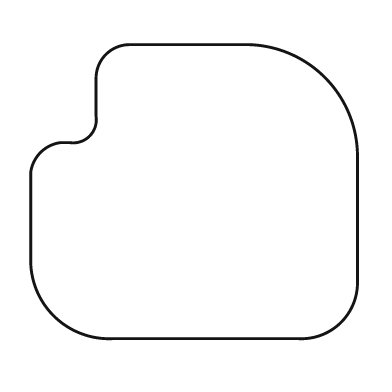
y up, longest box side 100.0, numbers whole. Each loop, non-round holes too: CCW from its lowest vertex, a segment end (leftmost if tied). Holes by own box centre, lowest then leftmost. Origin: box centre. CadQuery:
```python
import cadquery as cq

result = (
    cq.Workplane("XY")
    .moveTo(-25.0, -45.0)
    .lineTo(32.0, -45.0)
    .threePointArc((45.0, -40.0), (50.0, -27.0))
    .lineTo(50.0, 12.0)
    .threePointArc((40.0, 35.0), (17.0, 45.0))
    .lineTo(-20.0, 45.0)
    .threePointArc((-27.0, 42.0), (-30.0, 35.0))
    .lineTo(-30.0, 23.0)
    .threePointArc((-32.0, 17.0), (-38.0, 15.0))
    .lineTo(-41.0, 15.0)
    .threePointArc((-47.0, 12.0), (-50.0, 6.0))
    .lineTo(-50.0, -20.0)
    .threePointArc((-43.0, -38.0), (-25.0, -45.0))
    .close()
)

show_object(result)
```